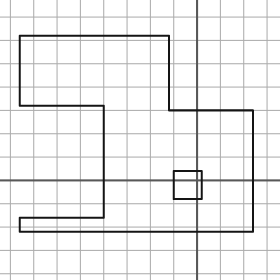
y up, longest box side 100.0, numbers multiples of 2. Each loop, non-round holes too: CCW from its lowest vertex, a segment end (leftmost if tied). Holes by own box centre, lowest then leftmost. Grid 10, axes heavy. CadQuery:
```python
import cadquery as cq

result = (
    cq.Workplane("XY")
    .moveTo(-76.0, -22.0)
    .lineTo(24.0, -22.0)
    .lineTo(24.0, 30.0)
    .lineTo(-12.0, 30.0)
    .lineTo(-12.0, 62.0)
    .lineTo(-76.0, 62.0)
    .lineTo(-76.0, 32.0)
    .lineTo(-40.0, 32.0)
    .lineTo(-40.0, -16.0)
    .lineTo(-76.0, -16.0)
    .close()
    .moveTo(-10.0, -8.0)
    .lineTo(2.0, -8.0)
    .lineTo(2.0, 4.0)
    .lineTo(-10.0, 4.0)
    .close()
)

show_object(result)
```